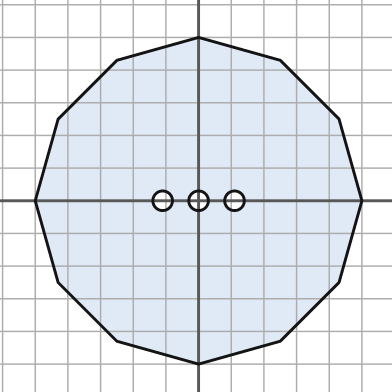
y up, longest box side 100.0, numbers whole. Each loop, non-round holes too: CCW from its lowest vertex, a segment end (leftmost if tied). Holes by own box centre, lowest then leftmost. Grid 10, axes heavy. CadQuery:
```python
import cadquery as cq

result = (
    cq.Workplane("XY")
    .moveTo(0.0, -50.0)
    .lineTo(25.0, -43.0)
    .lineTo(43.0, -25.0)
    .lineTo(50.0, 0.0)
    .lineTo(43.0, 25.0)
    .lineTo(25.0, 43.0)
    .lineTo(0.0, 50.0)
    .lineTo(-25.0, 43.0)
    .lineTo(-43.0, 25.0)
    .lineTo(-50.0, 0.0)
    .lineTo(-43.0, -25.0)
    .lineTo(-25.0, -43.0)
    .close()
    .moveTo(-11.0, 0.0)
    .circle(3.0)
    .moveTo(0.0, 0.0)
    .circle(3.0)
    .moveTo(11.0, 0.0)
    .circle(3.0)
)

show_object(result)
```